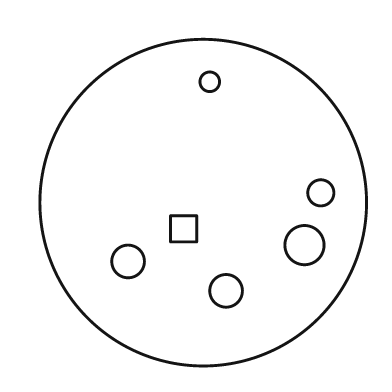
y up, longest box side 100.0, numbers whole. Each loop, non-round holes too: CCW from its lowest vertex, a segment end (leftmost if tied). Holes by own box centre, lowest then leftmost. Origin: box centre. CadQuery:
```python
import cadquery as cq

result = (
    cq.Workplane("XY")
    .moveTo(0.0, 0.0)
    .circle(50.0)
    .moveTo(7.0, -27.0)
    .circle(5.0)
    .moveTo(-23.0, -18.0)
    .circle(5.0)
    .moveTo(31.0, -13.0)
    .circle(6.0)
    .moveTo(-10.0, -12.0)
    .lineTo(-2.0, -12.0)
    .lineTo(-2.0, -4.0)
    .lineTo(-10.0, -4.0)
    .close()
    .moveTo(36.0, 3.0)
    .circle(4.0)
    .moveTo(2.0, 37.0)
    .circle(3.0)
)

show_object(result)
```